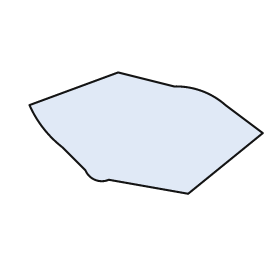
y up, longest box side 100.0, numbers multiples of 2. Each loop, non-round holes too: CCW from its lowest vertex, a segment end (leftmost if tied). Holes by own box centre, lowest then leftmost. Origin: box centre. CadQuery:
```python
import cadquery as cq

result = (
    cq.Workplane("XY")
    .moveTo(18.0, -26.0)
    .lineTo(50.0, 0.0)
    .lineTo(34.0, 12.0)
    .threePointArc((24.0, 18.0), (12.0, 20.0))
    .lineTo(-12.0, 26.0)
    .lineTo(-50.0, 12.0)
    .threePointArc((-44.0, 2.0), (-36.0, -6.0))
    .lineTo(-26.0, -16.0)
    .threePointArc((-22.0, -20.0), (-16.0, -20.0))
    .close()
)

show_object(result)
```